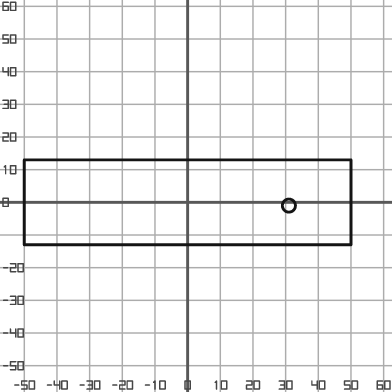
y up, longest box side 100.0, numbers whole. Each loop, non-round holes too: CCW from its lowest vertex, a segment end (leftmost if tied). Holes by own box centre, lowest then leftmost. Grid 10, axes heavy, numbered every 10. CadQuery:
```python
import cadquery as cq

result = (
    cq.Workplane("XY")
    .moveTo(-50.0, -13.0)
    .lineTo(50.0, -13.0)
    .lineTo(50.0, 13.0)
    .lineTo(-50.0, 13.0)
    .close()
    .moveTo(31.0, -1.0)
    .circle(2.0)
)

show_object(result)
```